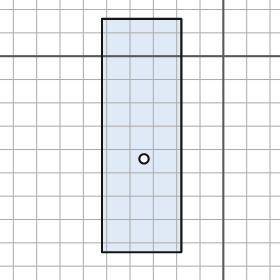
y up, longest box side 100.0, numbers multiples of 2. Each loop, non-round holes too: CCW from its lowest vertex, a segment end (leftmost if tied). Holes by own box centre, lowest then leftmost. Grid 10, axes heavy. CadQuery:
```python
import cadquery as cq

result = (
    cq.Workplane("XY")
    .moveTo(-52.0, -84.0)
    .lineTo(-18.0, -84.0)
    .lineTo(-18.0, 16.0)
    .lineTo(-52.0, 16.0)
    .close()
    .moveTo(-34.0, -44.0)
    .circle(2.0)
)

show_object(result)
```